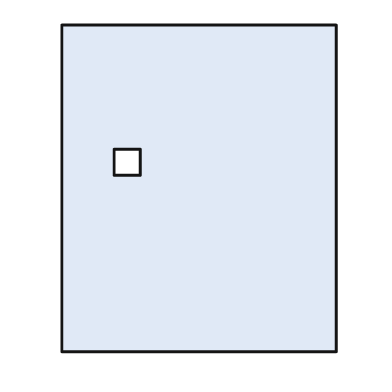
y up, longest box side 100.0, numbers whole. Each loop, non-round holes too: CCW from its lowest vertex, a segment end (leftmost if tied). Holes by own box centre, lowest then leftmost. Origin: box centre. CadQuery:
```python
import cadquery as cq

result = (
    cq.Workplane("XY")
    .moveTo(-42.0, -50.0)
    .lineTo(42.0, -50.0)
    .lineTo(42.0, 50.0)
    .lineTo(-42.0, 50.0)
    .close()
    .moveTo(-26.0, 4.0)
    .lineTo(-18.0, 4.0)
    .lineTo(-18.0, 12.0)
    .lineTo(-26.0, 12.0)
    .close()
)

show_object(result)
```